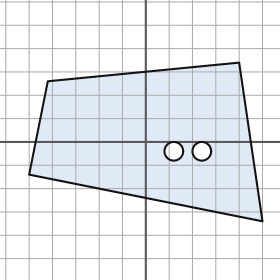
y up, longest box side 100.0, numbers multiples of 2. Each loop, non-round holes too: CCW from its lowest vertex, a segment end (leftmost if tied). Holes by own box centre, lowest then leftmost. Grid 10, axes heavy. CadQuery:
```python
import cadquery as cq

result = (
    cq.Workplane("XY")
    .moveTo(50.0, -34.0)
    .lineTo(40.0, 34.0)
    .lineTo(-42.0, 26.0)
    .lineTo(-50.0, -14.0)
    .close()
    .moveTo(12.0, -4.0)
    .circle(4.0)
    .moveTo(24.0, -4.0)
    .circle(4.0)
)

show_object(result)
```